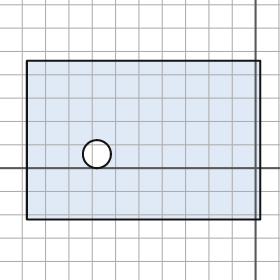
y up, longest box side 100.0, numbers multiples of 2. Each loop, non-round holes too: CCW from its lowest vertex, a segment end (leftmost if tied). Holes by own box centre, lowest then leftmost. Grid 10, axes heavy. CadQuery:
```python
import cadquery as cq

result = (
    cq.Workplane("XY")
    .moveTo(-98.0, -22.0)
    .lineTo(2.0, -22.0)
    .lineTo(2.0, 46.0)
    .lineTo(-98.0, 46.0)
    .close()
    .moveTo(-68.0, 6.0)
    .circle(6.0)
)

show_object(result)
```